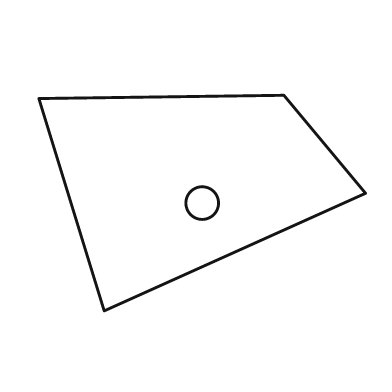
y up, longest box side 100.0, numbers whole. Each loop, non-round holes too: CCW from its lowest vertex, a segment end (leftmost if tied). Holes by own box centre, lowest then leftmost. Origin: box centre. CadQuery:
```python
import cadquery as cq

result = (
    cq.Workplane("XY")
    .moveTo(-30.0, -33.0)
    .lineTo(50.0, 3.0)
    .lineTo(25.0, 33.0)
    .lineTo(-50.0, 32.0)
    .close()
    .moveTo(0.0, 0.0)
    .circle(5.0)
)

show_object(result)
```